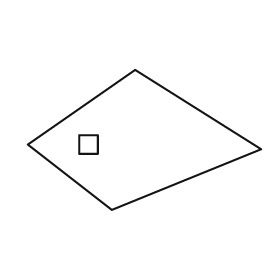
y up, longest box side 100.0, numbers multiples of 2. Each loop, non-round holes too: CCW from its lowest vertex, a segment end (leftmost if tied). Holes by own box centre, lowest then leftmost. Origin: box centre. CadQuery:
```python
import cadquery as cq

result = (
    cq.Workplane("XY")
    .moveTo(-14.0, -30.0)
    .lineTo(50.0, -4.0)
    .lineTo(-4.0, 30.0)
    .lineTo(-50.0, -2.0)
    .close()
    .moveTo(-28.0, -6.0)
    .lineTo(-20.0, -6.0)
    .lineTo(-20.0, 2.0)
    .lineTo(-28.0, 2.0)
    .close()
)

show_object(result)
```